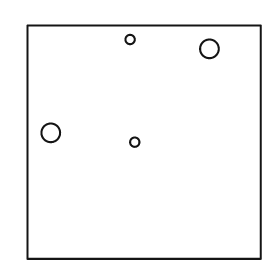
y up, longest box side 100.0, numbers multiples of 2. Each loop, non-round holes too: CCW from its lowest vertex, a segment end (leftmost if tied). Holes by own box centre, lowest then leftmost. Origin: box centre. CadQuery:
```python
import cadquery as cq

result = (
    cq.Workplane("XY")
    .moveTo(-50.0, -50.0)
    .lineTo(50.0, -50.0)
    .lineTo(50.0, 50.0)
    .lineTo(-50.0, 50.0)
    .close()
    .moveTo(-4.0, 0.0)
    .circle(2.0)
    .moveTo(-40.0, 4.0)
    .circle(4.0)
    .moveTo(28.0, 40.0)
    .circle(4.0)
    .moveTo(-6.0, 44.0)
    .circle(2.0)
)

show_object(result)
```